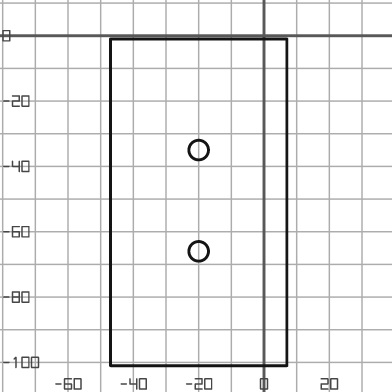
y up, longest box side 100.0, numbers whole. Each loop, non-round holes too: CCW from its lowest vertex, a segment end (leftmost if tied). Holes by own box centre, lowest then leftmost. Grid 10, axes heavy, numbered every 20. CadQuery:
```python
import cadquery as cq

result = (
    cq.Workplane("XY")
    .moveTo(-47.0, -101.0)
    .lineTo(7.0, -101.0)
    .lineTo(7.0, -1.0)
    .lineTo(-47.0, -1.0)
    .close()
    .moveTo(-20.0, -66.0)
    .circle(3.0)
    .moveTo(-20.0, -35.0)
    .circle(3.0)
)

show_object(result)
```